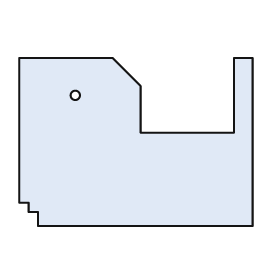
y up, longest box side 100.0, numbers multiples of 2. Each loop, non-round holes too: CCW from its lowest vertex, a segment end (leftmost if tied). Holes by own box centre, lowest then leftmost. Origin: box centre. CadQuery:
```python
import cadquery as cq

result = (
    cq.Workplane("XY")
    .moveTo(-42.0, -36.0)
    .lineTo(50.0, -36.0)
    .lineTo(50.0, 36.0)
    .lineTo(42.0, 36.0)
    .lineTo(42.0, 4.0)
    .lineTo(2.0, 4.0)
    .lineTo(2.0, 24.0)
    .lineTo(-10.0, 36.0)
    .lineTo(-50.0, 36.0)
    .lineTo(-50.0, -26.0)
    .lineTo(-46.0, -26.0)
    .lineTo(-46.0, -30.0)
    .lineTo(-42.0, -30.0)
    .close()
    .moveTo(-26.0, 20.0)
    .circle(2.0)
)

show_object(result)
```